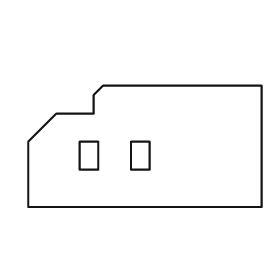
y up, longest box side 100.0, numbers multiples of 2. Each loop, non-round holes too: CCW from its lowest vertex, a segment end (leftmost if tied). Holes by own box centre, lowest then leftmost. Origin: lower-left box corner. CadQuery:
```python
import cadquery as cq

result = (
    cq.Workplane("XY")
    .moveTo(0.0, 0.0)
    .lineTo(100.0, 0.0)
    .lineTo(100.0, 52.0)
    .lineTo(32.0, 52.0)
    .lineTo(28.0, 48.0)
    .lineTo(28.0, 40.0)
    .lineTo(12.0, 40.0)
    .lineTo(0.0, 28.0)
    .close()
    .moveTo(22.0, 16.0)
    .lineTo(30.0, 16.0)
    .lineTo(30.0, 28.0)
    .lineTo(22.0, 28.0)
    .close()
    .moveTo(44.0, 16.0)
    .lineTo(52.0, 16.0)
    .lineTo(52.0, 28.0)
    .lineTo(44.0, 28.0)
    .close()
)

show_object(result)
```